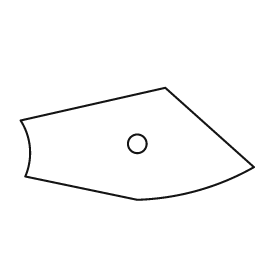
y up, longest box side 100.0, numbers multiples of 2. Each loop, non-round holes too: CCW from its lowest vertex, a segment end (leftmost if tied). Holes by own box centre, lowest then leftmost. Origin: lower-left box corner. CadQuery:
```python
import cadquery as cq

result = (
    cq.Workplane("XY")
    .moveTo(50.0, 0.0)
    .threePointArc((76.0, 4.0), (100.0, 14.0))
    .lineTo(62.0, 48.0)
    .lineTo(0.0, 34.0)
    .threePointArc((4.0, 22.0), (2.0, 10.0))
    .close()
    .moveTo(50.0, 24.0)
    .circle(4.0)
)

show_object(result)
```